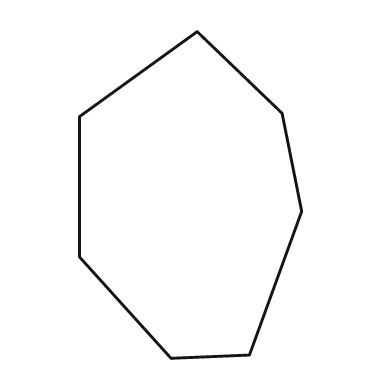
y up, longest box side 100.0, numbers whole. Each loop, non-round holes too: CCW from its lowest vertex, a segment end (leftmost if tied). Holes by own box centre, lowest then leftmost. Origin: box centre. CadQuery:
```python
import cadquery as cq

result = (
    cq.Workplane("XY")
    .moveTo(-6.0, -50.0)
    .lineTo(18.0, -49.0)
    .lineTo(34.0, -5.0)
    .lineTo(28.0, 25.0)
    .lineTo(2.0, 50.0)
    .lineTo(-34.0, 24.0)
    .lineTo(-34.0, -19.0)
    .close()
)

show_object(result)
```